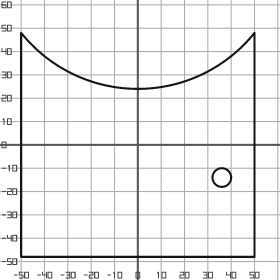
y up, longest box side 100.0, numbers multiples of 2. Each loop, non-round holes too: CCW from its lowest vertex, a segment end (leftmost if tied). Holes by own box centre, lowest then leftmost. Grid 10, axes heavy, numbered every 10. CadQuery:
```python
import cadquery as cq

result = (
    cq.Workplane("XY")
    .moveTo(-50.0, -48.0)
    .lineTo(50.0, -48.0)
    .lineTo(50.0, 48.0)
    .threePointArc((0.0, 24.0), (-50.0, 48.0))
    .close()
    .moveTo(36.0, -14.0)
    .circle(4.0)
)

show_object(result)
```